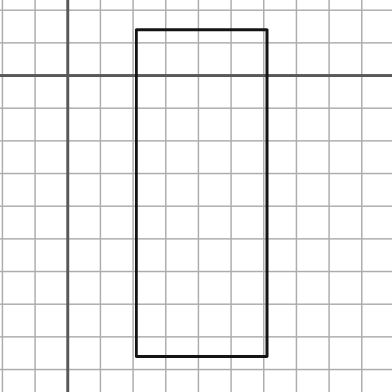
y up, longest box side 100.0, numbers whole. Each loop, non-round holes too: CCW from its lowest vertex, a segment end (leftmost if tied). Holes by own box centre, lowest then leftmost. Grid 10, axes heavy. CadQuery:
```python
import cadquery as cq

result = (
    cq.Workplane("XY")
    .moveTo(21.0, -86.0)
    .lineTo(61.0, -86.0)
    .lineTo(61.0, 14.0)
    .lineTo(21.0, 14.0)
    .close()
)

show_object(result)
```